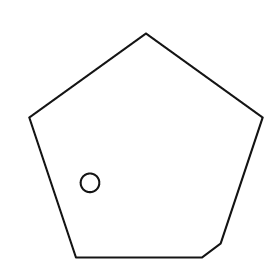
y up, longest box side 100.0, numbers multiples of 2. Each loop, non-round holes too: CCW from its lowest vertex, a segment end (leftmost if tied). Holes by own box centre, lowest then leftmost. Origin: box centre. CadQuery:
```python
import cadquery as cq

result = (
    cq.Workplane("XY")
    .moveTo(-30.0, -48.0)
    .lineTo(24.0, -48.0)
    .lineTo(32.0, -42.0)
    .lineTo(50.0, 12.0)
    .lineTo(0.0, 48.0)
    .lineTo(-50.0, 12.0)
    .close()
    .moveTo(-24.0, -16.0)
    .circle(4.0)
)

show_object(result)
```